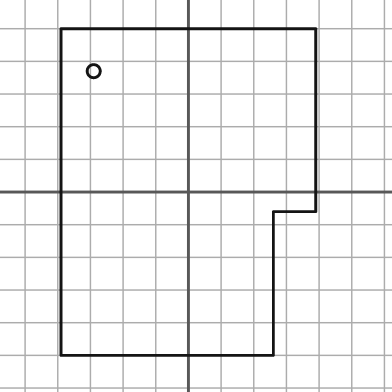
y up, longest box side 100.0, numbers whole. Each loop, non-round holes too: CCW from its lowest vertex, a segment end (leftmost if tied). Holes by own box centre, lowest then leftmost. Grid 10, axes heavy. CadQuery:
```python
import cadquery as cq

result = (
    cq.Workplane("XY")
    .moveTo(-39.0, -50.0)
    .lineTo(26.0, -50.0)
    .lineTo(26.0, -6.0)
    .lineTo(39.0, -6.0)
    .lineTo(39.0, 50.0)
    .lineTo(-39.0, 50.0)
    .close()
    .moveTo(-29.0, 37.0)
    .circle(2.0)
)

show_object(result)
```